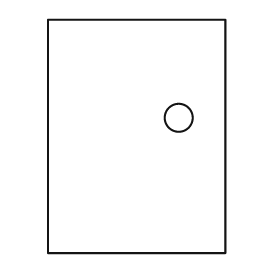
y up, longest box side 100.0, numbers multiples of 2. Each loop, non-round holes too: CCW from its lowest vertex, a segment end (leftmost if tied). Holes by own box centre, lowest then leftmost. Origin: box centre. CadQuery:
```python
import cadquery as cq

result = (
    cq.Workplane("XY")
    .moveTo(-38.0, -50.0)
    .lineTo(38.0, -50.0)
    .lineTo(38.0, 50.0)
    .lineTo(-38.0, 50.0)
    .close()
    .moveTo(18.0, 8.0)
    .circle(6.0)
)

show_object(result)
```